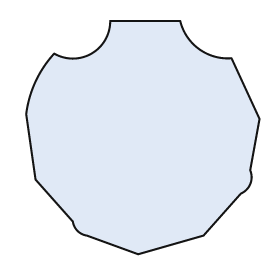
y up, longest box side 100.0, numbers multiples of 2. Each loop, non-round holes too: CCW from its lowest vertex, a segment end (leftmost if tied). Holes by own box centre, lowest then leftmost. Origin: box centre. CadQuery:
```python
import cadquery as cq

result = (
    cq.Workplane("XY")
    .moveTo(-2.0, -50.0)
    .lineTo(26.0, -42.0)
    .lineTo(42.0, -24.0)
    .threePointArc((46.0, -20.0), (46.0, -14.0))
    .lineTo(50.0, 8.0)
    .lineTo(38.0, 34.0)
    .threePointArc((24.0, 38.0), (16.0, 50.0))
    .lineTo(-14.0, 50.0)
    .threePointArc((-22.0, 36.0), (-38.0, 36.0))
    .threePointArc((-46.0, 24.0), (-50.0, 10.0))
    .lineTo(-46.0, -18.0)
    .lineTo(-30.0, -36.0)
    .threePointArc((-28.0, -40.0), (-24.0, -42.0))
    .close()
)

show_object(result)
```